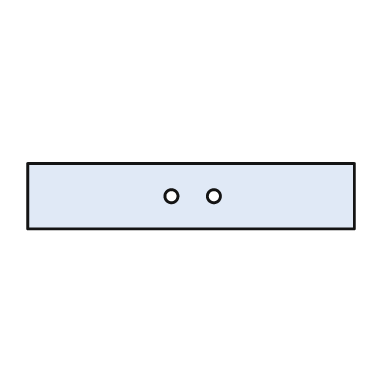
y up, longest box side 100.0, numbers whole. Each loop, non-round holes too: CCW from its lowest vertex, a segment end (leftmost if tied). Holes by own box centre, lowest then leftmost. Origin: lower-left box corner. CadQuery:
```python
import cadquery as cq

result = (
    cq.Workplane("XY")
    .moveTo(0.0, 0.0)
    .lineTo(100.0, 0.0)
    .lineTo(100.0, 20.0)
    .lineTo(0.0, 20.0)
    .close()
    .moveTo(44.0, 10.0)
    .circle(2.0)
    .moveTo(57.0, 10.0)
    .circle(2.0)
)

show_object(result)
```